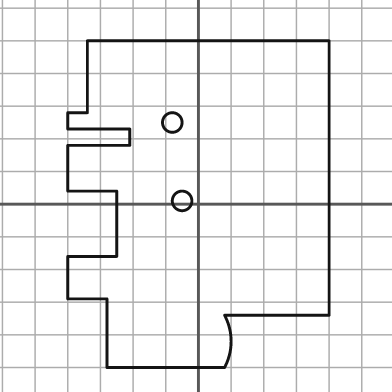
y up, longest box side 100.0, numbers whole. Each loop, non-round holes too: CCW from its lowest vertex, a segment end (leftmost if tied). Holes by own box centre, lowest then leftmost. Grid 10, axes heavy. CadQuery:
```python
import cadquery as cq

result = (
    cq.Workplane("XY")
    .moveTo(-28.0, -50.0)
    .lineTo(8.0, -50.0)
    .threePointArc((10.0, -42.0), (8.0, -34.0))
    .lineTo(40.0, -34.0)
    .lineTo(40.0, 50.0)
    .lineTo(-34.0, 50.0)
    .lineTo(-34.0, 28.0)
    .lineTo(-40.0, 28.0)
    .lineTo(-40.0, 23.0)
    .lineTo(-21.0, 23.0)
    .lineTo(-21.0, 18.0)
    .lineTo(-40.0, 18.0)
    .lineTo(-40.0, 4.0)
    .lineTo(-25.0, 4.0)
    .lineTo(-25.0, -16.0)
    .lineTo(-40.0, -16.0)
    .lineTo(-40.0, -29.0)
    .lineTo(-28.0, -29.0)
    .close()
    .moveTo(-5.0, 1.0)
    .circle(3.0)
    .moveTo(-8.0, 25.0)
    .circle(3.0)
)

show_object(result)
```